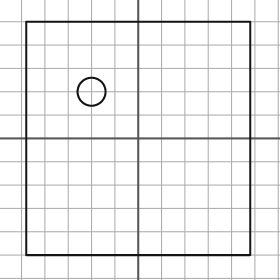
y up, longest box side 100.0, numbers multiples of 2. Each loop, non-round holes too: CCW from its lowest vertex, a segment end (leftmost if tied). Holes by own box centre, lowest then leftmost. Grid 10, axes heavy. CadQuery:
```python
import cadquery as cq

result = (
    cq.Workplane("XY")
    .moveTo(-48.0, -50.0)
    .lineTo(48.0, -50.0)
    .lineTo(48.0, 50.0)
    .lineTo(-48.0, 50.0)
    .close()
    .moveTo(-20.0, 20.0)
    .circle(6.0)
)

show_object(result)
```